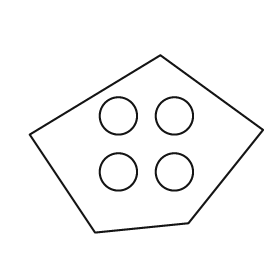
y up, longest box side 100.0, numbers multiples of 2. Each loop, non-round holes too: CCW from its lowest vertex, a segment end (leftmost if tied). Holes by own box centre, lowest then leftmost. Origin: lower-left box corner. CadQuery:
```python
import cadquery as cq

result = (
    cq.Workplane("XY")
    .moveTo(28.0, 0.0)
    .lineTo(68.0, 4.0)
    .lineTo(100.0, 44.0)
    .lineTo(56.0, 76.0)
    .lineTo(0.0, 42.0)
    .close()
    .moveTo(38.0, 26.0)
    .circle(8.0)
    .moveTo(62.0, 26.0)
    .circle(8.0)
    .moveTo(38.0, 50.0)
    .circle(8.0)
    .moveTo(62.0, 50.0)
    .circle(8.0)
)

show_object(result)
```